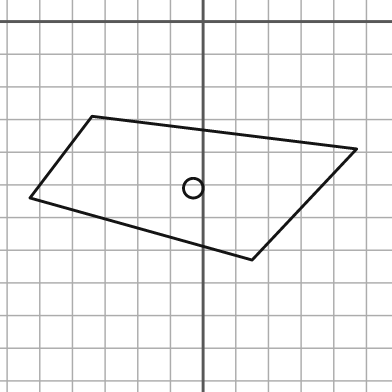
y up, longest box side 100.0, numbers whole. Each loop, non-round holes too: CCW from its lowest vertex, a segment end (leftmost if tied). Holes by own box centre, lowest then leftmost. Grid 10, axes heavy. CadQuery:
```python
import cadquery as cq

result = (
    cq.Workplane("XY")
    .moveTo(15.0, -73.0)
    .lineTo(47.0, -39.0)
    .lineTo(-34.0, -29.0)
    .lineTo(-53.0, -54.0)
    .close()
    .moveTo(-3.0, -51.0)
    .circle(3.0)
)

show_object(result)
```